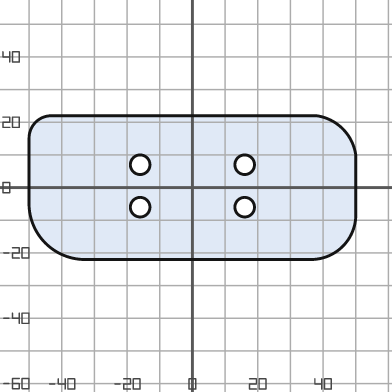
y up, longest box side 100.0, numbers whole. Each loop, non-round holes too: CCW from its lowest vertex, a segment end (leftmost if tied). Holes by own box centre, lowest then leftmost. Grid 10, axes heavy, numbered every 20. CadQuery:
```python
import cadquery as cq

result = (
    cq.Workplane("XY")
    .moveTo(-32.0, -22.0)
    .lineTo(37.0, -22.0)
    .threePointArc((46.0, -18.0), (50.0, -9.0))
    .lineTo(50.0, 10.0)
    .threePointArc((46.0, 18.0), (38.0, 22.0))
    .lineTo(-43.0, 22.0)
    .threePointArc((-48.0, 20.0), (-50.0, 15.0))
    .lineTo(-50.0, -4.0)
    .threePointArc((-45.0, -17.0), (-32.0, -22.0))
    .close()
    .moveTo(-16.0, -6.0)
    .circle(3.0)
    .moveTo(16.0, -6.0)
    .circle(3.0)
    .moveTo(-16.0, 7.0)
    .circle(3.0)
    .moveTo(16.0, 7.0)
    .circle(3.0)
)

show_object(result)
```